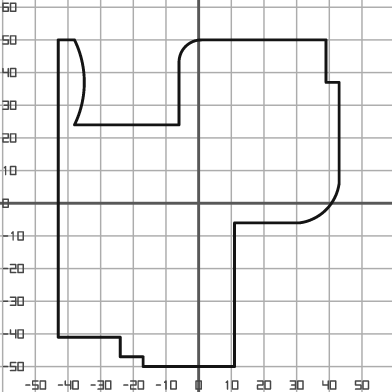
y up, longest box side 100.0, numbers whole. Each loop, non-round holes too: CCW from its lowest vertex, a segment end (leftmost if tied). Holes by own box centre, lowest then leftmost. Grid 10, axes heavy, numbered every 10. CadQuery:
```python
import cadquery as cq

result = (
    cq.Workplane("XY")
    .moveTo(-17.0, -50.0)
    .lineTo(11.0, -50.0)
    .lineTo(11.0, -6.0)
    .lineTo(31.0, -6.0)
    .threePointArc((39.0, -2.0), (43.0, 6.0))
    .lineTo(43.0, 37.0)
    .lineTo(39.0, 37.0)
    .lineTo(39.0, 50.0)
    .lineTo(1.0, 50.0)
    .threePointArc((-4.0, 48.0), (-6.0, 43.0))
    .lineTo(-6.0, 24.0)
    .lineTo(-38.0, 24.0)
    .threePointArc((-35.0, 37.0), (-38.0, 50.0))
    .lineTo(-43.0, 50.0)
    .lineTo(-43.0, -41.0)
    .lineTo(-24.0, -41.0)
    .lineTo(-24.0, -47.0)
    .lineTo(-17.0, -47.0)
    .close()
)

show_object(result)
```